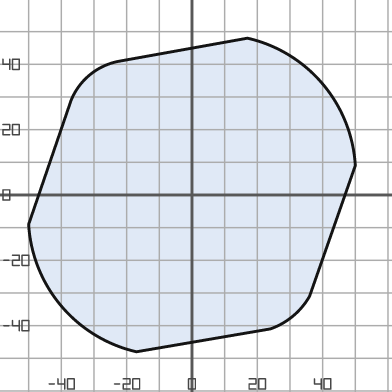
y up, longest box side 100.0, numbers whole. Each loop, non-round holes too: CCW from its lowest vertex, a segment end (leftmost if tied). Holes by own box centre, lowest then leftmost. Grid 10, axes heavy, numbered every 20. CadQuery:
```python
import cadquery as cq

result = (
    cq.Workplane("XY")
    .moveTo(-17.0, -48.0)
    .lineTo(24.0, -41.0)
    .threePointArc((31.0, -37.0), (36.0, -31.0))
    .lineTo(50.0, 9.0)
    .threePointArc((40.0, 34.0), (17.0, 48.0))
    .lineTo(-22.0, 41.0)
    .threePointArc((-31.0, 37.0), (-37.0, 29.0))
    .lineTo(-50.0, -9.0)
    .threePointArc((-40.0, -34.0), (-17.0, -48.0))
    .close()
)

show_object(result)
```